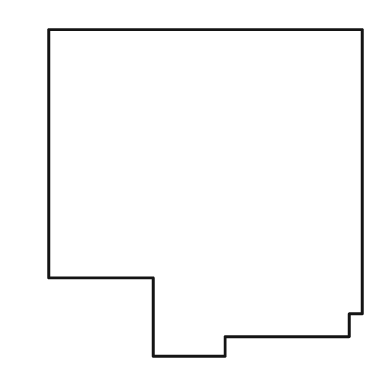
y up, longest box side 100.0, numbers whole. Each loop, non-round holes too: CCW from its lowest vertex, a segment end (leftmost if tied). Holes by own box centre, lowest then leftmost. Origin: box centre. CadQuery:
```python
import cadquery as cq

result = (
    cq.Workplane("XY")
    .moveTo(-16.0, -50.0)
    .lineTo(6.0, -50.0)
    .lineTo(6.0, -44.0)
    .lineTo(44.0, -44.0)
    .lineTo(44.0, -37.0)
    .lineTo(48.0, -37.0)
    .lineTo(48.0, 50.0)
    .lineTo(-48.0, 50.0)
    .lineTo(-48.0, -26.0)
    .lineTo(-16.0, -26.0)
    .close()
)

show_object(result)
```